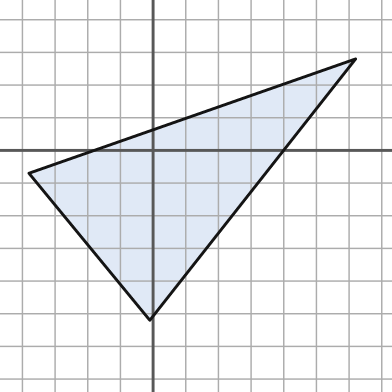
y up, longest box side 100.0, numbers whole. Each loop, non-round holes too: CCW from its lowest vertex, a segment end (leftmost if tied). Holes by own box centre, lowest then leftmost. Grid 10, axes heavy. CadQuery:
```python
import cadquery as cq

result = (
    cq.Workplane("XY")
    .moveTo(-1.0, -52.0)
    .lineTo(62.0, 28.0)
    .lineTo(-38.0, -7.0)
    .close()
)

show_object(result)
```